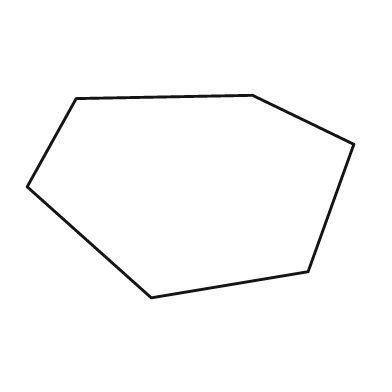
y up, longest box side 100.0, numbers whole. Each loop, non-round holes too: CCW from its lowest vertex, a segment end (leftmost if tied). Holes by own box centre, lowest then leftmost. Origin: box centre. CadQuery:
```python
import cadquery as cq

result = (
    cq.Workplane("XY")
    .moveTo(-12.0, -31.0)
    .lineTo(36.0, -23.0)
    .lineTo(50.0, 16.0)
    .lineTo(19.0, 31.0)
    .lineTo(-35.0, 30.0)
    .lineTo(-50.0, 3.0)
    .close()
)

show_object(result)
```